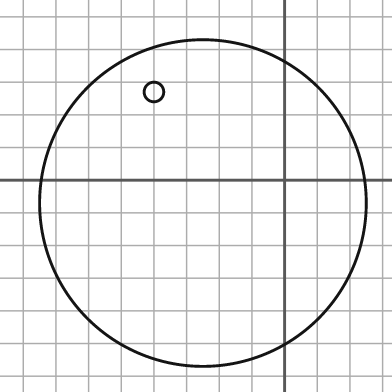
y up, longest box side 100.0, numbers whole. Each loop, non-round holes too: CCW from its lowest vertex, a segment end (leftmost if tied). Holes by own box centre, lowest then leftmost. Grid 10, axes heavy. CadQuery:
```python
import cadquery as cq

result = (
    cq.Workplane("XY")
    .moveTo(-25.0, -7.0)
    .circle(50.0)
    .moveTo(-40.0, 27.0)
    .circle(3.0)
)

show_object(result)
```